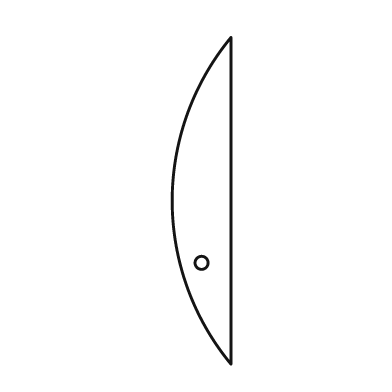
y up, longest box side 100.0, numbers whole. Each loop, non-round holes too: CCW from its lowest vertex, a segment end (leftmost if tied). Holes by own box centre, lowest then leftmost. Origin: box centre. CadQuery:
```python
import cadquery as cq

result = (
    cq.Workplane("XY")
    .moveTo(9.0, -50.0)
    .lineTo(9.0, 50.0)
    .threePointArc((-9.0, 0.0), (9.0, -50.0))
    .close()
    .moveTo(0.0, -19.0)
    .circle(2.0)
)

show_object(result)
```